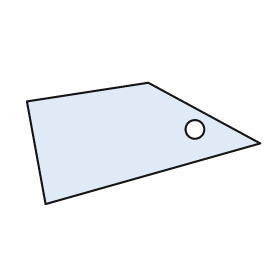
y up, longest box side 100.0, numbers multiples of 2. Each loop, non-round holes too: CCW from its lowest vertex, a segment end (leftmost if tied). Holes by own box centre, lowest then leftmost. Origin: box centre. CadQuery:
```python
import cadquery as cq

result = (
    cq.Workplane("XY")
    .moveTo(-42.0, -26.0)
    .lineTo(50.0, 0.0)
    .lineTo(2.0, 26.0)
    .lineTo(-50.0, 18.0)
    .close()
    .moveTo(22.0, 6.0)
    .circle(4.0)
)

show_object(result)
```